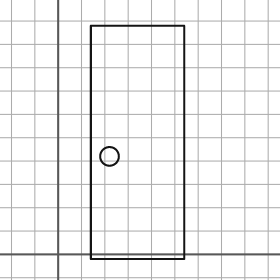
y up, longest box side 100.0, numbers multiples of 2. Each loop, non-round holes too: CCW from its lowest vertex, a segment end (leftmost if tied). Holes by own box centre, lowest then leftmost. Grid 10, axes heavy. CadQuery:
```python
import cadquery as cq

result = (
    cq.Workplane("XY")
    .moveTo(14.0, -2.0)
    .lineTo(54.0, -2.0)
    .lineTo(54.0, 98.0)
    .lineTo(14.0, 98.0)
    .close()
    .moveTo(22.0, 42.0)
    .circle(4.0)
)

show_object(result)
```